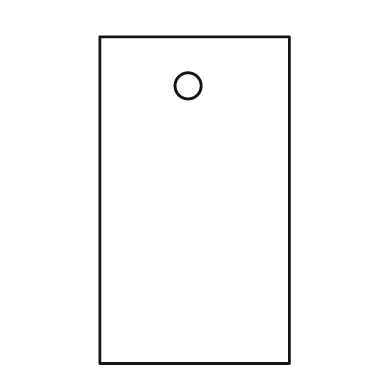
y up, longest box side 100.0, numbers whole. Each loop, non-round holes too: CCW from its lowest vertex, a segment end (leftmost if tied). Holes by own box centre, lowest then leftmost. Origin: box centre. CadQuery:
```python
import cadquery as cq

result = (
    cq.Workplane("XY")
    .moveTo(-29.0, -50.0)
    .lineTo(29.0, -50.0)
    .lineTo(29.0, 50.0)
    .lineTo(-29.0, 50.0)
    .close()
    .moveTo(-2.0, 35.0)
    .circle(4.0)
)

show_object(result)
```